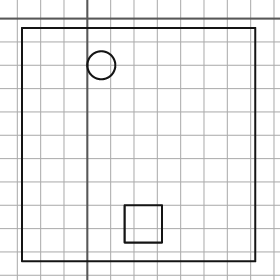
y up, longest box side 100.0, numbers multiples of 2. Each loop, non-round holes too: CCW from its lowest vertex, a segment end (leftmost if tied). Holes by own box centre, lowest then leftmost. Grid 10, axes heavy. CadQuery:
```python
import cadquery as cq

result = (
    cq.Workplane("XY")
    .moveTo(-28.0, -104.0)
    .lineTo(72.0, -104.0)
    .lineTo(72.0, -4.0)
    .lineTo(-28.0, -4.0)
    .close()
    .moveTo(16.0, -96.0)
    .lineTo(32.0, -96.0)
    .lineTo(32.0, -80.0)
    .lineTo(16.0, -80.0)
    .close()
    .moveTo(6.0, -20.0)
    .circle(6.0)
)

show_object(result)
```